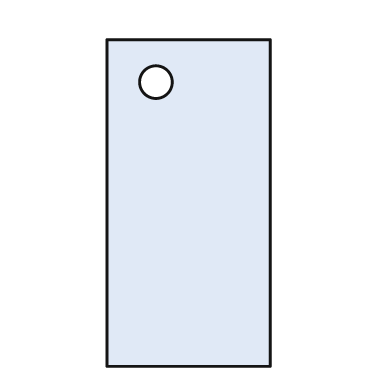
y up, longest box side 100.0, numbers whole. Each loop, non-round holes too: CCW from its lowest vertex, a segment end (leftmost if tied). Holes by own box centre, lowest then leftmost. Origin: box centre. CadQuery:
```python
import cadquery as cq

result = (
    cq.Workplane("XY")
    .moveTo(-25.0, -50.0)
    .lineTo(25.0, -50.0)
    .lineTo(25.0, 50.0)
    .lineTo(-25.0, 50.0)
    .close()
    .moveTo(-10.0, 37.0)
    .circle(5.0)
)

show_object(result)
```